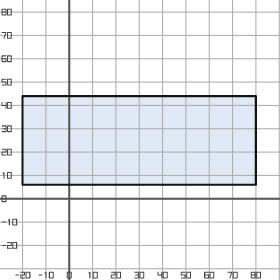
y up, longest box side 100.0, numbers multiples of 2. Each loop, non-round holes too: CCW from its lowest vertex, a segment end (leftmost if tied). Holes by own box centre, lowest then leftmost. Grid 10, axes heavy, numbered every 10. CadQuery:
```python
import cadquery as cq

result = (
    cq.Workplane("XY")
    .moveTo(-20.0, 6.0)
    .lineTo(80.0, 6.0)
    .lineTo(80.0, 44.0)
    .lineTo(-20.0, 44.0)
    .close()
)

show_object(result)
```